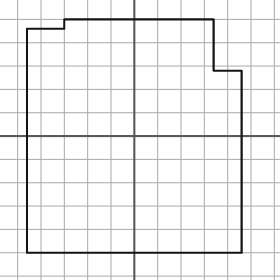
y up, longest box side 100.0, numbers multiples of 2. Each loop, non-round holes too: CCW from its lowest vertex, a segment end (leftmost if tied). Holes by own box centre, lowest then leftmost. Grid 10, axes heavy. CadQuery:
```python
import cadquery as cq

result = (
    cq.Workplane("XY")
    .moveTo(-46.0, -50.0)
    .lineTo(46.0, -50.0)
    .lineTo(46.0, 28.0)
    .lineTo(34.0, 28.0)
    .lineTo(34.0, 50.0)
    .lineTo(-30.0, 50.0)
    .lineTo(-30.0, 46.0)
    .lineTo(-46.0, 46.0)
    .close()
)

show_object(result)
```